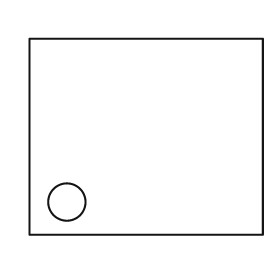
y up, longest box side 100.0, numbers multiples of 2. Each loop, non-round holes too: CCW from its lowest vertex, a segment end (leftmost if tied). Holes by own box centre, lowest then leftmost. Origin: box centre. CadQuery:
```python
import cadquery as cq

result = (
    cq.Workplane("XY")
    .moveTo(-50.0, -42.0)
    .lineTo(50.0, -42.0)
    .lineTo(50.0, 42.0)
    .lineTo(-50.0, 42.0)
    .close()
    .moveTo(-34.0, -28.0)
    .circle(8.0)
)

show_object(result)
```